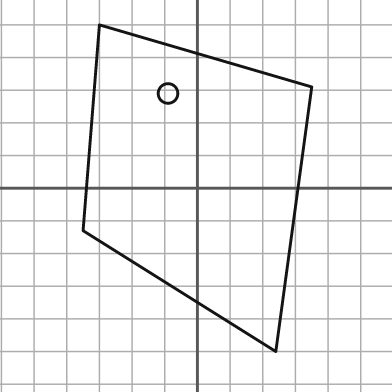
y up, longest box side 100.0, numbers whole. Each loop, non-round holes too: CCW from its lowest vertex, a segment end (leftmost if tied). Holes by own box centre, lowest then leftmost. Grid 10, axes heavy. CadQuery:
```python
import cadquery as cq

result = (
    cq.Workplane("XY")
    .moveTo(24.0, -50.0)
    .lineTo(35.0, 31.0)
    .lineTo(-30.0, 50.0)
    .lineTo(-35.0, -13.0)
    .close()
    .moveTo(-9.0, 29.0)
    .circle(3.0)
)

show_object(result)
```